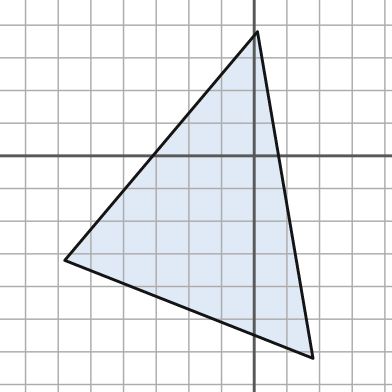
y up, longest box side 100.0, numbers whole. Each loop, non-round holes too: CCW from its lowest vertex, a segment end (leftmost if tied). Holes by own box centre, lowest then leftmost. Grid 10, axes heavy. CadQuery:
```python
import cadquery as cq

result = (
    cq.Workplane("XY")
    .moveTo(18.0, -62.0)
    .lineTo(1.0, 38.0)
    .lineTo(-58.0, -32.0)
    .close()
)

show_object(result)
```